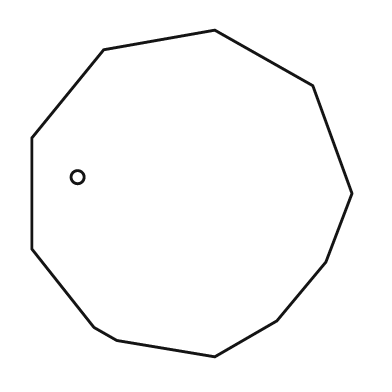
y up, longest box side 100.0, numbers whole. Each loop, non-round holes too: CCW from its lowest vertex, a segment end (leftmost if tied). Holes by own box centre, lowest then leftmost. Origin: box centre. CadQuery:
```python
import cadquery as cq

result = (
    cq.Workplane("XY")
    .moveTo(7.0, -50.0)
    .lineTo(26.0, -39.0)
    .lineTo(41.0, -21.0)
    .lineTo(49.0, 0.0)
    .lineTo(37.0, 33.0)
    .lineTo(7.0, 50.0)
    .lineTo(-27.0, 44.0)
    .lineTo(-49.0, 17.0)
    .lineTo(-49.0, -17.0)
    .lineTo(-30.0, -41.0)
    .lineTo(-23.0, -45.0)
    .close()
    .moveTo(-35.0, 5.0)
    .circle(2.0)
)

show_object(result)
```